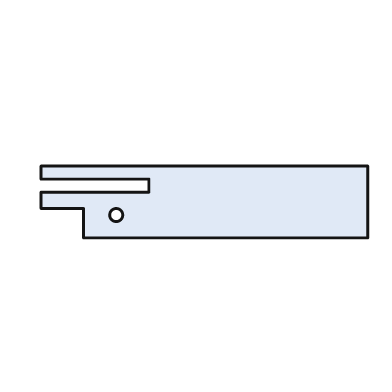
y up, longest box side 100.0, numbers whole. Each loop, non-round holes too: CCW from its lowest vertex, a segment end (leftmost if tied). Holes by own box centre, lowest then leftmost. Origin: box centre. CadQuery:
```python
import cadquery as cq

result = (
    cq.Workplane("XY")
    .moveTo(-37.0, -11.0)
    .lineTo(50.0, -11.0)
    .lineTo(50.0, 11.0)
    .lineTo(-50.0, 11.0)
    .lineTo(-50.0, 7.0)
    .lineTo(-17.0, 7.0)
    .lineTo(-17.0, 3.0)
    .lineTo(-50.0, 3.0)
    .lineTo(-50.0, -2.0)
    .lineTo(-37.0, -2.0)
    .close()
    .moveTo(-27.0, -4.0)
    .circle(2.0)
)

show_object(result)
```